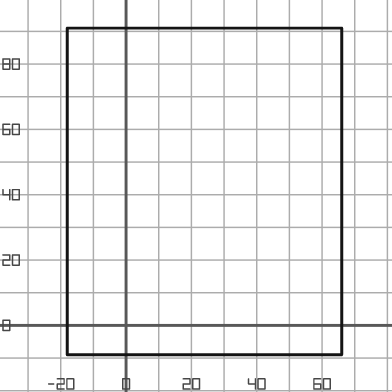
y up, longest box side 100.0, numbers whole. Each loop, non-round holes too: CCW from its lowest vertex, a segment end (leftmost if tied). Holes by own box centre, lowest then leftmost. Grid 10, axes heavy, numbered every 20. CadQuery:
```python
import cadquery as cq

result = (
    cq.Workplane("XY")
    .moveTo(-18.0, -9.0)
    .lineTo(66.0, -9.0)
    .lineTo(66.0, 91.0)
    .lineTo(-18.0, 91.0)
    .close()
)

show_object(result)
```